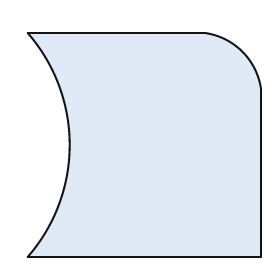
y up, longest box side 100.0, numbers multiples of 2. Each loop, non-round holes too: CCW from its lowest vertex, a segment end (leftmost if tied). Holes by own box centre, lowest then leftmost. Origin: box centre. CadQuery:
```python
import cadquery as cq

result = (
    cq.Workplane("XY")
    .moveTo(-50.0, -48.0)
    .lineTo(50.0, -48.0)
    .lineTo(50.0, 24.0)
    .threePointArc((42.0, 40.0), (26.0, 48.0))
    .lineTo(-50.0, 48.0)
    .threePointArc((-32.0, 0.0), (-50.0, -48.0))
    .close()
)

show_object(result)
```